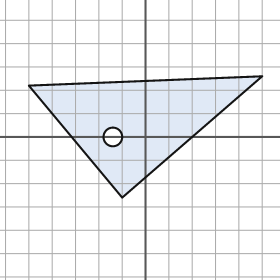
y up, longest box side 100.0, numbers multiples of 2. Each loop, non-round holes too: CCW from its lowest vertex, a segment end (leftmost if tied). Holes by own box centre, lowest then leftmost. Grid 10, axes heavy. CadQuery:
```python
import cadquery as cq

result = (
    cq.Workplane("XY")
    .moveTo(-10.0, -26.0)
    .lineTo(50.0, 26.0)
    .lineTo(-50.0, 22.0)
    .close()
    .moveTo(-14.0, 0.0)
    .circle(4.0)
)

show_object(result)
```